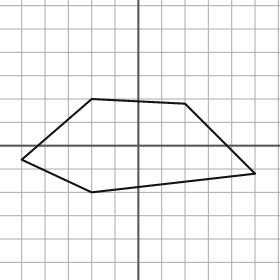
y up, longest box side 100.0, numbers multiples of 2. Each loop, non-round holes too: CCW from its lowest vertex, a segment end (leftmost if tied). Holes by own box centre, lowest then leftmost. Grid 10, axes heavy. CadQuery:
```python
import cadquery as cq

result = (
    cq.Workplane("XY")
    .moveTo(-20.0, -20.0)
    .lineTo(50.0, -12.0)
    .lineTo(20.0, 18.0)
    .lineTo(-20.0, 20.0)
    .lineTo(-50.0, -6.0)
    .close()
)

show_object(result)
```